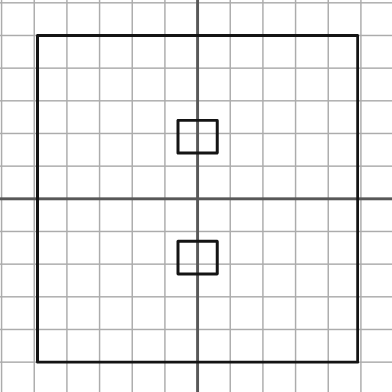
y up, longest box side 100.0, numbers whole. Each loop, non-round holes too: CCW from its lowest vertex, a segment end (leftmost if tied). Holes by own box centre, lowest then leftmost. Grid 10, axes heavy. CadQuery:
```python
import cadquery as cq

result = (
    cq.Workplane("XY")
    .moveTo(-49.0, -50.0)
    .lineTo(49.0, -50.0)
    .lineTo(49.0, 50.0)
    .lineTo(-49.0, 50.0)
    .close()
    .moveTo(-6.0, -23.0)
    .lineTo(6.0, -23.0)
    .lineTo(6.0, -13.0)
    .lineTo(-6.0, -13.0)
    .close()
    .moveTo(-6.0, 14.0)
    .lineTo(6.0, 14.0)
    .lineTo(6.0, 24.0)
    .lineTo(-6.0, 24.0)
    .close()
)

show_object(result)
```